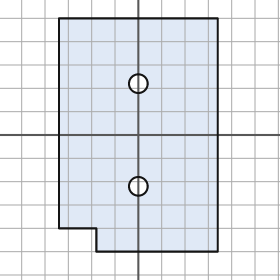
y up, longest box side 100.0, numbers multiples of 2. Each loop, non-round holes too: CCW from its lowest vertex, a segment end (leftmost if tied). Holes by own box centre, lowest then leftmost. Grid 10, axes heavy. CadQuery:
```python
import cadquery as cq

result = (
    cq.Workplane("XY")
    .moveTo(-18.0, -50.0)
    .lineTo(34.0, -50.0)
    .lineTo(34.0, 50.0)
    .lineTo(-34.0, 50.0)
    .lineTo(-34.0, -40.0)
    .lineTo(-18.0, -40.0)
    .close()
    .moveTo(0.0, -22.0)
    .circle(4.0)
    .moveTo(0.0, 22.0)
    .circle(4.0)
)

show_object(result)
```